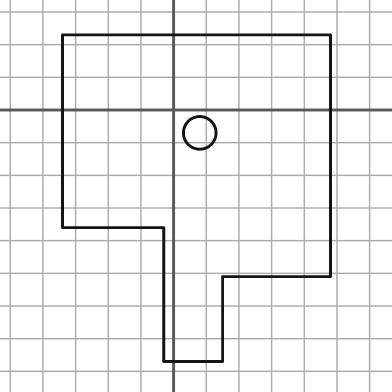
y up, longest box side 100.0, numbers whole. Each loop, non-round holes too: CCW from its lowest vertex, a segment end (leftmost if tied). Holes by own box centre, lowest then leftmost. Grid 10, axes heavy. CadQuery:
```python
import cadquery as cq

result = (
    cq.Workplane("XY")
    .moveTo(-3.0, -77.0)
    .lineTo(15.0, -77.0)
    .lineTo(15.0, -51.0)
    .lineTo(48.0, -51.0)
    .lineTo(48.0, 23.0)
    .lineTo(-34.0, 23.0)
    .lineTo(-34.0, -36.0)
    .lineTo(-3.0, -36.0)
    .close()
    .moveTo(8.0, -7.0)
    .circle(5.0)
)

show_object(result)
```